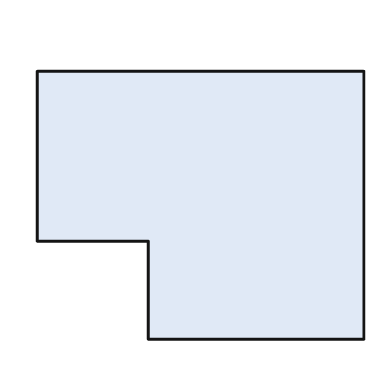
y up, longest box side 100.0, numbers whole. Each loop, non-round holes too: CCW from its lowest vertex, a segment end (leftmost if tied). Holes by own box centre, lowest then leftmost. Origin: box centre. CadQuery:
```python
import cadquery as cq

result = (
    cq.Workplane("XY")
    .moveTo(-16.0, -41.0)
    .lineTo(50.0, -41.0)
    .lineTo(50.0, 41.0)
    .lineTo(-50.0, 41.0)
    .lineTo(-50.0, -11.0)
    .lineTo(-16.0, -11.0)
    .close()
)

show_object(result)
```